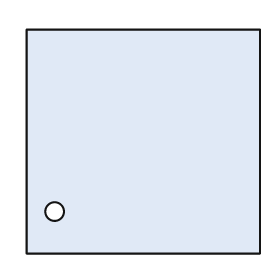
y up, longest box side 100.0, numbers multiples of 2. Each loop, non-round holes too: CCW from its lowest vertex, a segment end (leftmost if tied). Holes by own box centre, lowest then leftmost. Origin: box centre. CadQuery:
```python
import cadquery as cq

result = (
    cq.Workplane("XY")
    .moveTo(-50.0, -48.0)
    .lineTo(50.0, -48.0)
    .lineTo(50.0, 48.0)
    .lineTo(-50.0, 48.0)
    .close()
    .moveTo(-38.0, -30.0)
    .circle(4.0)
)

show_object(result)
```